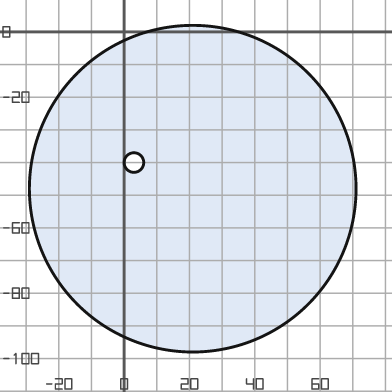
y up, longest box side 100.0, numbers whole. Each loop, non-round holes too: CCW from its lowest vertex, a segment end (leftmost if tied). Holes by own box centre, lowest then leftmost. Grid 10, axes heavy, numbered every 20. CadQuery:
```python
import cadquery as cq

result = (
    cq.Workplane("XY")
    .moveTo(21.0, -48.0)
    .circle(50.0)
    .moveTo(3.0, -40.0)
    .circle(3.0)
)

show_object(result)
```